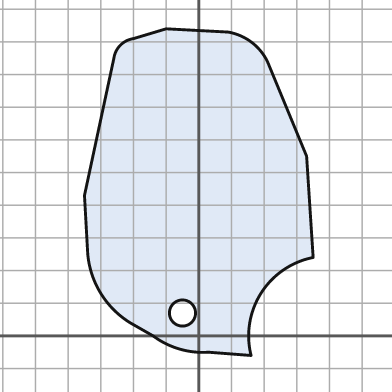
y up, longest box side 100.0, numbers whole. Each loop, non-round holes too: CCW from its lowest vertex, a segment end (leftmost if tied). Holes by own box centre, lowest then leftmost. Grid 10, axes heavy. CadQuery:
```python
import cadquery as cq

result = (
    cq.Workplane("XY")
    .moveTo(16.0, -6.0)
    .threePointArc((19.0, 13.0), (35.0, 24.0))
    .lineTo(33.0, 55.0)
    .lineTo(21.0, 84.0)
    .threePointArc((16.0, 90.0), (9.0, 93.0))
    .lineTo(-10.0, 94.0)
    .lineTo(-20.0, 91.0)
    .threePointArc((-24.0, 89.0), (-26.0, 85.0))
    .lineTo(-35.0, 43.0)
    .lineTo(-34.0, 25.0)
    .threePointArc((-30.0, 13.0), (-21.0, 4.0))
    .lineTo(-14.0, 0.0)
    .threePointArc((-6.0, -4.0), (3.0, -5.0))
    .close()
    .moveTo(-5.0, 7.0)
    .circle(4.0)
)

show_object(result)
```